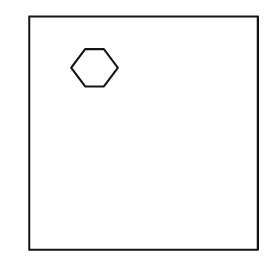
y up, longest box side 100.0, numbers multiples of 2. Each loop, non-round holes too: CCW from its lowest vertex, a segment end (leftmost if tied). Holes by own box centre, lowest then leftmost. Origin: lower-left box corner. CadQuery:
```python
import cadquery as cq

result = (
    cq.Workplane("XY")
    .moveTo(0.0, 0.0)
    .lineTo(98.0, 0.0)
    .lineTo(98.0, 100.0)
    .lineTo(0.0, 100.0)
    .close()
    .moveTo(24.0, 70.0)
    .lineTo(32.0, 70.0)
    .lineTo(38.0, 78.0)
    .lineTo(32.0, 86.0)
    .lineTo(24.0, 86.0)
    .lineTo(18.0, 78.0)
    .close()
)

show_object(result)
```